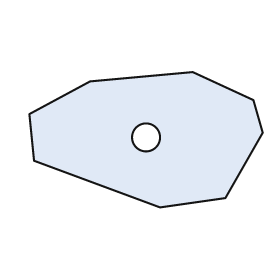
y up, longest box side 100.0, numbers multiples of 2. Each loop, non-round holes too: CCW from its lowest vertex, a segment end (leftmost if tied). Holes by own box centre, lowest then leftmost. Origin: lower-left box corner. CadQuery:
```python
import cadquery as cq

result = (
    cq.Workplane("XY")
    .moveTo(56.0, 0.0)
    .lineTo(84.0, 4.0)
    .lineTo(100.0, 32.0)
    .lineTo(96.0, 46.0)
    .lineTo(70.0, 58.0)
    .lineTo(26.0, 54.0)
    .lineTo(0.0, 40.0)
    .lineTo(2.0, 20.0)
    .close()
    .moveTo(50.0, 30.0)
    .circle(6.0)
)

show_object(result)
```